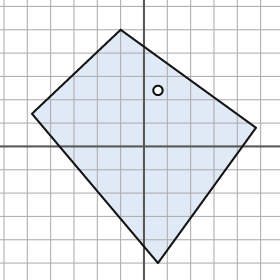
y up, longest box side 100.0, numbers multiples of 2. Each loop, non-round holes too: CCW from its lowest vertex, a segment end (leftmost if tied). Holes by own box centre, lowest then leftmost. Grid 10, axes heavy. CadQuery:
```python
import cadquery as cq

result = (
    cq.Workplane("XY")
    .moveTo(6.0, -50.0)
    .lineTo(48.0, 8.0)
    .lineTo(-10.0, 50.0)
    .lineTo(-48.0, 14.0)
    .close()
    .moveTo(6.0, 24.0)
    .circle(2.0)
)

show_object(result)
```